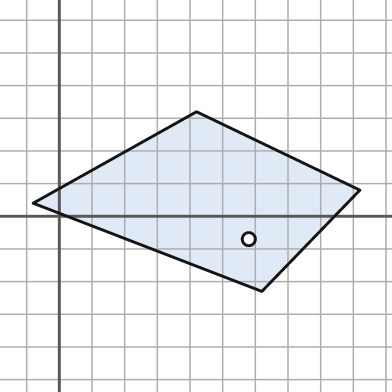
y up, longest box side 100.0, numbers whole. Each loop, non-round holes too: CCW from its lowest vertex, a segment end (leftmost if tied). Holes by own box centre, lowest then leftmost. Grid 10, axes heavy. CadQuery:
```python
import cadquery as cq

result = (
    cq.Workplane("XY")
    .moveTo(62.0, -23.0)
    .lineTo(92.0, 8.0)
    .lineTo(42.0, 32.0)
    .lineTo(-8.0, 4.0)
    .close()
    .moveTo(58.0, -7.0)
    .circle(2.0)
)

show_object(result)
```